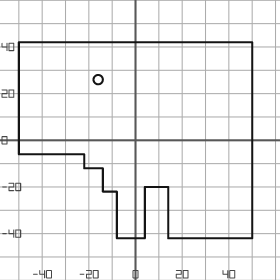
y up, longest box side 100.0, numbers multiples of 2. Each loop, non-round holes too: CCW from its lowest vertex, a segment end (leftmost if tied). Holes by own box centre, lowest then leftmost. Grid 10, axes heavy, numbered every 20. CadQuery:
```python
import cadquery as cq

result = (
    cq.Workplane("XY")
    .moveTo(-8.0, -42.0)
    .lineTo(4.0, -42.0)
    .lineTo(4.0, -20.0)
    .lineTo(14.0, -20.0)
    .lineTo(14.0, -42.0)
    .lineTo(50.0, -42.0)
    .lineTo(50.0, 42.0)
    .lineTo(-50.0, 42.0)
    .lineTo(-50.0, -6.0)
    .lineTo(-22.0, -6.0)
    .lineTo(-22.0, -12.0)
    .lineTo(-14.0, -12.0)
    .lineTo(-14.0, -22.0)
    .lineTo(-8.0, -22.0)
    .close()
    .moveTo(-16.0, 26.0)
    .circle(2.0)
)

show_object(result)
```